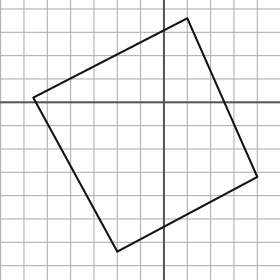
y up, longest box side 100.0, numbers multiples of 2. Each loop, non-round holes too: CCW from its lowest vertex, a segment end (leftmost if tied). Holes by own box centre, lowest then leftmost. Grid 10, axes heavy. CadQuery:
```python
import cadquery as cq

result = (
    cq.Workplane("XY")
    .moveTo(-20.0, -64.0)
    .lineTo(40.0, -32.0)
    .lineTo(10.0, 36.0)
    .lineTo(-56.0, 2.0)
    .close()
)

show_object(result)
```